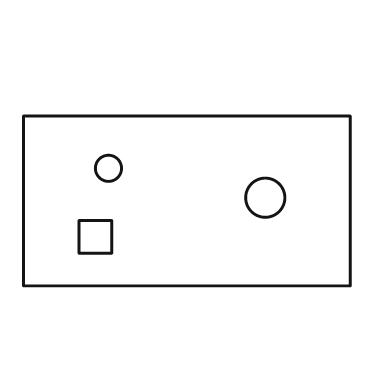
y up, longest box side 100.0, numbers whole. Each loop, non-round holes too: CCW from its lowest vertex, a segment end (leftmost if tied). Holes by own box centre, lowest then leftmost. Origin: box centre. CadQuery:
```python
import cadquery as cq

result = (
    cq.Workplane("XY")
    .moveTo(-50.0, -26.0)
    .lineTo(50.0, -26.0)
    .lineTo(50.0, 26.0)
    .lineTo(-50.0, 26.0)
    .close()
    .moveTo(-33.0, -16.0)
    .lineTo(-23.0, -16.0)
    .lineTo(-23.0, -6.0)
    .lineTo(-33.0, -6.0)
    .close()
    .moveTo(24.0, 1.0)
    .circle(6.0)
    .moveTo(-24.0, 10.0)
    .circle(4.0)
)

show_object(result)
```